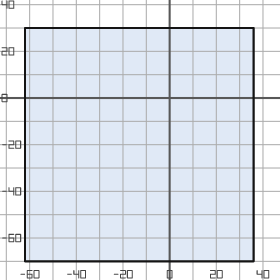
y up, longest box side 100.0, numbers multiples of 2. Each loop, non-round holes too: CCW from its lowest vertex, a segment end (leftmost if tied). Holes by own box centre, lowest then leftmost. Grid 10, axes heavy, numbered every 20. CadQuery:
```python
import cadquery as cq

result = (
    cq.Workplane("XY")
    .moveTo(-62.0, -70.0)
    .lineTo(36.0, -70.0)
    .lineTo(36.0, 30.0)
    .lineTo(-62.0, 30.0)
    .close()
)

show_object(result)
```